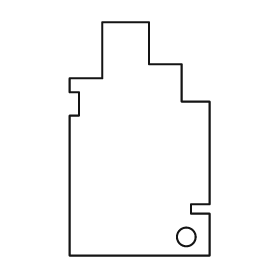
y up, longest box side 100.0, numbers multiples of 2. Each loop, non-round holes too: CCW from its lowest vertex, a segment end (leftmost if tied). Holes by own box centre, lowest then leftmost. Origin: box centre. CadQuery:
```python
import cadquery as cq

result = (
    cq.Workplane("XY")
    .moveTo(-30.0, -50.0)
    .lineTo(30.0, -50.0)
    .lineTo(30.0, -32.0)
    .lineTo(22.0, -32.0)
    .lineTo(22.0, -28.0)
    .lineTo(30.0, -28.0)
    .lineTo(30.0, 16.0)
    .lineTo(18.0, 16.0)
    .lineTo(18.0, 32.0)
    .lineTo(4.0, 32.0)
    .lineTo(4.0, 50.0)
    .lineTo(-16.0, 50.0)
    .lineTo(-16.0, 26.0)
    .lineTo(-30.0, 26.0)
    .lineTo(-30.0, 20.0)
    .lineTo(-26.0, 20.0)
    .lineTo(-26.0, 10.0)
    .lineTo(-30.0, 10.0)
    .close()
    .moveTo(20.0, -42.0)
    .circle(4.0)
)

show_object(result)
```